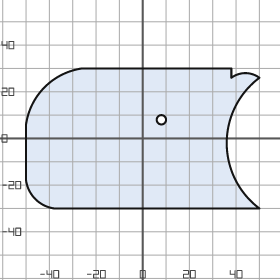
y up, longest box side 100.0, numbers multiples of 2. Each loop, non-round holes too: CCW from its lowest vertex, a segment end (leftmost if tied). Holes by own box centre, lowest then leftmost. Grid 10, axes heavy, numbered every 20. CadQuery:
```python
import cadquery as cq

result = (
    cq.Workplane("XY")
    .moveTo(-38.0, -30.0)
    .lineTo(50.0, -30.0)
    .threePointArc((36.0, -2.0), (50.0, 26.0))
    .threePointArc((44.0, 28.0), (38.0, 26.0))
    .lineTo(38.0, 30.0)
    .lineTo(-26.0, 30.0)
    .threePointArc((-42.0, 22.0), (-50.0, 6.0))
    .lineTo(-50.0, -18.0)
    .threePointArc((-46.0, -26.0), (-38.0, -30.0))
    .close()
    .moveTo(8.0, 8.0)
    .circle(2.0)
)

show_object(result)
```